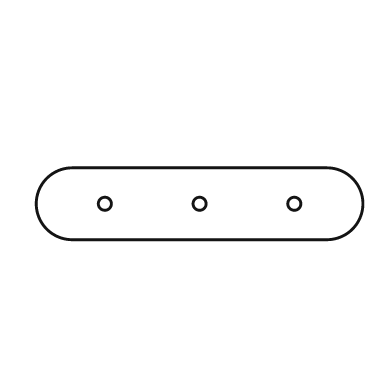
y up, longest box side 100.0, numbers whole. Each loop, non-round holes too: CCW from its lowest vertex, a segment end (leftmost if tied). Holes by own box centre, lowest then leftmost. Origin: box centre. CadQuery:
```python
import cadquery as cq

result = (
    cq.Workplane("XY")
    .moveTo(-39.0, -11.0)
    .lineTo(39.0, -11.0)
    .threePointArc((50.0, 0.0), (39.0, 11.0))
    .lineTo(-39.0, 11.0)
    .threePointArc((-50.0, 0.0), (-39.0, -11.0))
    .close()
    .moveTo(-29.0, 0.0)
    .circle(2.0)
    .moveTo(0.0, 0.0)
    .circle(2.0)
    .moveTo(29.0, 0.0)
    .circle(2.0)
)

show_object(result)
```